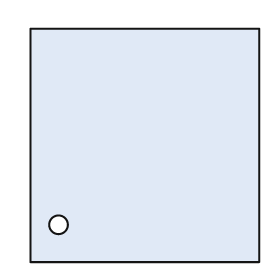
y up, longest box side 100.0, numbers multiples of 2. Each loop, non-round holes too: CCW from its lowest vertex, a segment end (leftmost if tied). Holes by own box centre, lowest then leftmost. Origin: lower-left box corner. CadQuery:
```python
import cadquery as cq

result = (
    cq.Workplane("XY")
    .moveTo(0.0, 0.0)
    .lineTo(98.0, 0.0)
    .lineTo(98.0, 100.0)
    .lineTo(0.0, 100.0)
    .close()
    .moveTo(12.0, 16.0)
    .circle(4.0)
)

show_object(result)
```